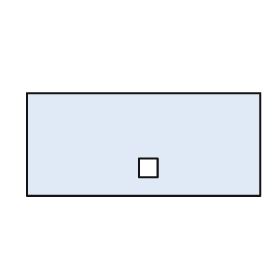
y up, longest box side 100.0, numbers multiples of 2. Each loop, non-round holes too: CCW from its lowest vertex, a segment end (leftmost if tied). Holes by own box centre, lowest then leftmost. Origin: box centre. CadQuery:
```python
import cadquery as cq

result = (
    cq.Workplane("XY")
    .moveTo(-50.0, -22.0)
    .lineTo(50.0, -22.0)
    .lineTo(50.0, 22.0)
    .lineTo(-50.0, 22.0)
    .close()
    .moveTo(-2.0, -14.0)
    .lineTo(6.0, -14.0)
    .lineTo(6.0, -6.0)
    .lineTo(-2.0, -6.0)
    .close()
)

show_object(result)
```